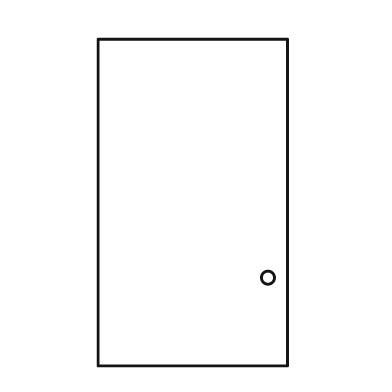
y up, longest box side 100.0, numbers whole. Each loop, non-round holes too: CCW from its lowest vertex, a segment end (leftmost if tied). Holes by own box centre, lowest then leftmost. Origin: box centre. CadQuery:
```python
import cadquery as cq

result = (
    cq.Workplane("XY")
    .moveTo(-29.0, -50.0)
    .lineTo(29.0, -50.0)
    .lineTo(29.0, 50.0)
    .lineTo(-29.0, 50.0)
    .close()
    .moveTo(23.0, -23.0)
    .circle(2.0)
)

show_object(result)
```